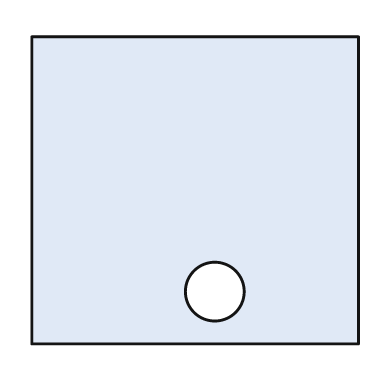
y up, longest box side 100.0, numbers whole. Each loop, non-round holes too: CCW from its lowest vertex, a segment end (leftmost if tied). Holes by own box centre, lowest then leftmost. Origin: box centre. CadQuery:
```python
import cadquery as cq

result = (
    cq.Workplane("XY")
    .moveTo(-50.0, -47.0)
    .lineTo(50.0, -47.0)
    .lineTo(50.0, 47.0)
    .lineTo(-50.0, 47.0)
    .close()
    .moveTo(6.0, -31.0)
    .circle(9.0)
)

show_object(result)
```